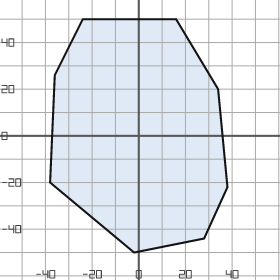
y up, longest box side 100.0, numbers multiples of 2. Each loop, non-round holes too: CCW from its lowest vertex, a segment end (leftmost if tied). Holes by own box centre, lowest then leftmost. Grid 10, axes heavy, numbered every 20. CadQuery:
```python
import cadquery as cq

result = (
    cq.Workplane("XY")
    .moveTo(-2.0, -50.0)
    .lineTo(28.0, -44.0)
    .lineTo(38.0, -22.0)
    .lineTo(34.0, 20.0)
    .lineTo(16.0, 50.0)
    .lineTo(-24.0, 50.0)
    .lineTo(-36.0, 26.0)
    .lineTo(-38.0, -20.0)
    .close()
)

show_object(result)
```